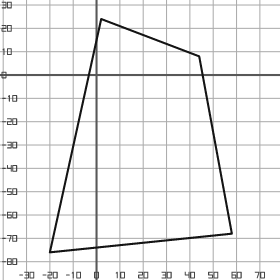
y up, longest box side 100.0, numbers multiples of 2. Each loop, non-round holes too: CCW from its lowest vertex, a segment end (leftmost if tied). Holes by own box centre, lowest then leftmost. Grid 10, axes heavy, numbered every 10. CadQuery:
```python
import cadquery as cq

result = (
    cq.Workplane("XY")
    .moveTo(-20.0, -76.0)
    .lineTo(58.0, -68.0)
    .lineTo(44.0, 8.0)
    .lineTo(2.0, 24.0)
    .close()
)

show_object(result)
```